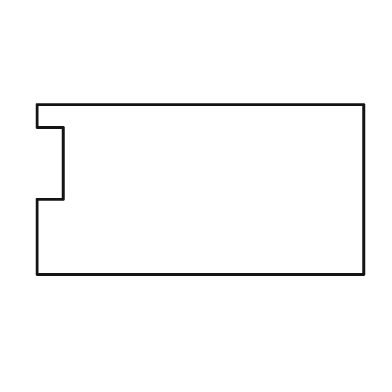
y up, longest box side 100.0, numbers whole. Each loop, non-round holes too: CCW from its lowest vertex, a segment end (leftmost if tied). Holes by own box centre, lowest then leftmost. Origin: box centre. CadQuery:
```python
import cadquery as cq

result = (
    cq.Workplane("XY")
    .moveTo(-50.0, -26.0)
    .lineTo(50.0, -26.0)
    .lineTo(50.0, 26.0)
    .lineTo(-50.0, 26.0)
    .lineTo(-50.0, 19.0)
    .lineTo(-42.0, 19.0)
    .lineTo(-42.0, -3.0)
    .lineTo(-50.0, -3.0)
    .close()
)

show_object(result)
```